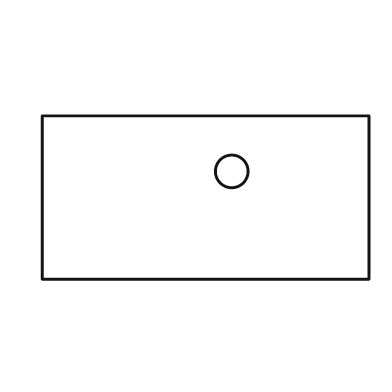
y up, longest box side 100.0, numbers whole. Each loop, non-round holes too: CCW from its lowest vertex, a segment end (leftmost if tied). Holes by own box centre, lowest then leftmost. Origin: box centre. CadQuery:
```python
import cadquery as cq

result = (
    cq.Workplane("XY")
    .moveTo(-50.0, -25.0)
    .lineTo(50.0, -25.0)
    .lineTo(50.0, 25.0)
    .lineTo(-50.0, 25.0)
    .close()
    .moveTo(8.0, 8.0)
    .circle(5.0)
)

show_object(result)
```